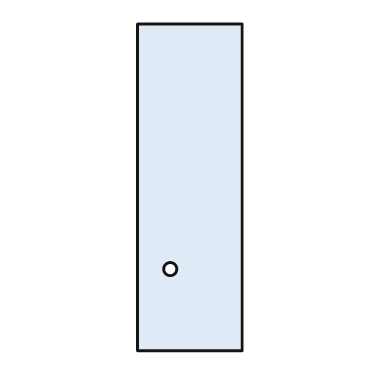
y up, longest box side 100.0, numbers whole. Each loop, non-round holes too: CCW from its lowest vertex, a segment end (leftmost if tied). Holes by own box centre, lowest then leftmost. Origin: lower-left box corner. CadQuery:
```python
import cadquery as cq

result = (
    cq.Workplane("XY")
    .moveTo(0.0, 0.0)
    .lineTo(32.0, 0.0)
    .lineTo(32.0, 100.0)
    .lineTo(0.0, 100.0)
    .close()
    .moveTo(10.0, 25.0)
    .circle(2.0)
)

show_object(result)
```